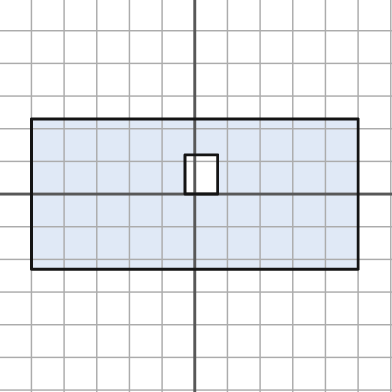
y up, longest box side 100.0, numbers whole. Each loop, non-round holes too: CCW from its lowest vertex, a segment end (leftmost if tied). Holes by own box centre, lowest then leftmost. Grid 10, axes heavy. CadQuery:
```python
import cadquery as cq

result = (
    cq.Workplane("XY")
    .moveTo(-50.0, -23.0)
    .lineTo(50.0, -23.0)
    .lineTo(50.0, 23.0)
    .lineTo(-50.0, 23.0)
    .close()
    .moveTo(-3.0, 0.0)
    .lineTo(7.0, 0.0)
    .lineTo(7.0, 12.0)
    .lineTo(-3.0, 12.0)
    .close()
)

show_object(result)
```